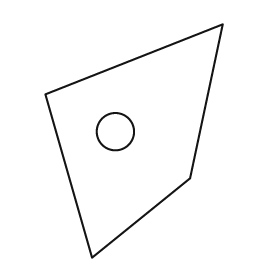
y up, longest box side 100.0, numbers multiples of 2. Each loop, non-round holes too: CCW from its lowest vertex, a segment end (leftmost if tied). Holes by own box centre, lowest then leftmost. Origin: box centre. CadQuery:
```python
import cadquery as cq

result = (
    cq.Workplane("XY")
    .moveTo(-18.0, -50.0)
    .lineTo(24.0, -16.0)
    .lineTo(38.0, 50.0)
    .lineTo(-38.0, 20.0)
    .close()
    .moveTo(-8.0, 4.0)
    .circle(8.0)
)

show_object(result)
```